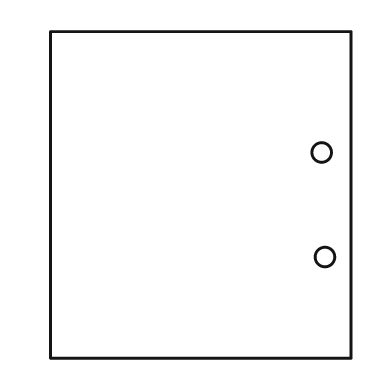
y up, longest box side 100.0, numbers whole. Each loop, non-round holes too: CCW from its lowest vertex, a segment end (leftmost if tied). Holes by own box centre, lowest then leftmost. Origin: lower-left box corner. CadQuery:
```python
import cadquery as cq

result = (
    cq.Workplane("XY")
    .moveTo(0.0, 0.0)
    .lineTo(92.0, 0.0)
    .lineTo(92.0, 100.0)
    .lineTo(0.0, 100.0)
    .close()
    .moveTo(84.0, 31.0)
    .circle(3.0)
    .moveTo(83.0, 63.0)
    .circle(3.0)
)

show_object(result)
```